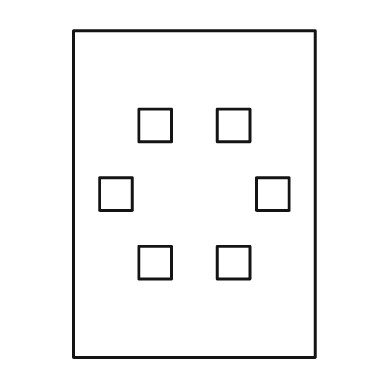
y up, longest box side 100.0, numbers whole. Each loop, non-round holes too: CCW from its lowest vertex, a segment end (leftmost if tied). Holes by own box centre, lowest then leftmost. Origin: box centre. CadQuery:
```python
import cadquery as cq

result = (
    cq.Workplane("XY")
    .moveTo(-37.0, -50.0)
    .lineTo(37.0, -50.0)
    .lineTo(37.0, 50.0)
    .lineTo(-37.0, 50.0)
    .close()
    .moveTo(-17.0, -26.0)
    .lineTo(-7.0, -26.0)
    .lineTo(-7.0, -16.0)
    .lineTo(-17.0, -16.0)
    .close()
    .moveTo(7.0, -26.0)
    .lineTo(17.0, -26.0)
    .lineTo(17.0, -16.0)
    .lineTo(7.0, -16.0)
    .close()
    .moveTo(-29.0, -5.0)
    .lineTo(-19.0, -5.0)
    .lineTo(-19.0, 5.0)
    .lineTo(-29.0, 5.0)
    .close()
    .moveTo(19.0, -5.0)
    .lineTo(29.0, -5.0)
    .lineTo(29.0, 5.0)
    .lineTo(19.0, 5.0)
    .close()
    .moveTo(-17.0, 16.0)
    .lineTo(-7.0, 16.0)
    .lineTo(-7.0, 26.0)
    .lineTo(-17.0, 26.0)
    .close()
    .moveTo(7.0, 16.0)
    .lineTo(17.0, 16.0)
    .lineTo(17.0, 26.0)
    .lineTo(7.0, 26.0)
    .close()
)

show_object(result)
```